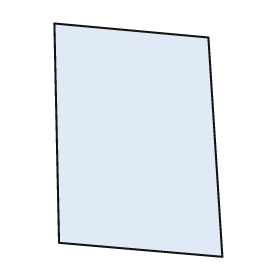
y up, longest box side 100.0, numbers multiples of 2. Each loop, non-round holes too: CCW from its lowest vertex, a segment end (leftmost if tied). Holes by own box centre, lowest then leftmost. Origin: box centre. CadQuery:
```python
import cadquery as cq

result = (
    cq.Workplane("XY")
    .moveTo(36.0, -50.0)
    .lineTo(30.0, 44.0)
    .lineTo(-36.0, 50.0)
    .lineTo(-34.0, -44.0)
    .close()
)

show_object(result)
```